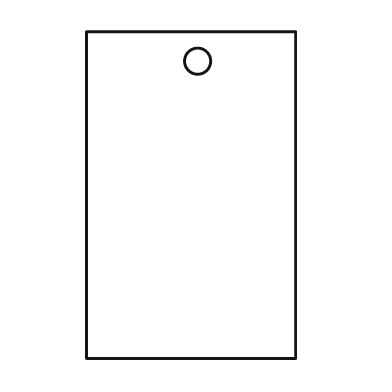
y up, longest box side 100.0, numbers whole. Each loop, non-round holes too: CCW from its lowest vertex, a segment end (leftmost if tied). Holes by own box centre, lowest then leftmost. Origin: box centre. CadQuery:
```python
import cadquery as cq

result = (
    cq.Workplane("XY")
    .moveTo(-32.0, -50.0)
    .lineTo(32.0, -50.0)
    .lineTo(32.0, 50.0)
    .lineTo(-32.0, 50.0)
    .close()
    .moveTo(2.0, 41.0)
    .circle(4.0)
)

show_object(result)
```